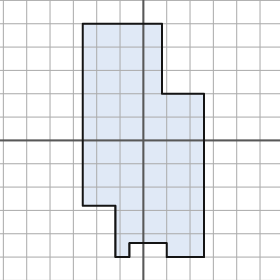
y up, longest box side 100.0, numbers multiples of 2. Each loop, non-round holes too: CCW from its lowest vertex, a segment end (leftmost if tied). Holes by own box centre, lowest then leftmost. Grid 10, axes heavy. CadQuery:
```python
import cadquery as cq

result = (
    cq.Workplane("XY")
    .moveTo(-12.0, -50.0)
    .lineTo(-6.0, -50.0)
    .lineTo(-6.0, -44.0)
    .lineTo(10.0, -44.0)
    .lineTo(10.0, -50.0)
    .lineTo(26.0, -50.0)
    .lineTo(26.0, 20.0)
    .lineTo(8.0, 20.0)
    .lineTo(8.0, 50.0)
    .lineTo(-26.0, 50.0)
    .lineTo(-26.0, -28.0)
    .lineTo(-12.0, -28.0)
    .close()
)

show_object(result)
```